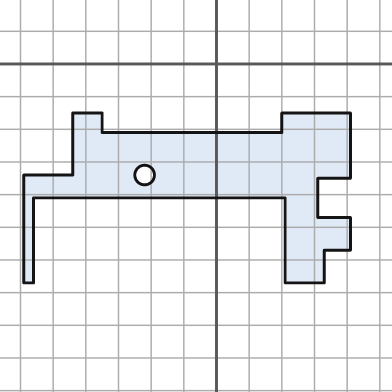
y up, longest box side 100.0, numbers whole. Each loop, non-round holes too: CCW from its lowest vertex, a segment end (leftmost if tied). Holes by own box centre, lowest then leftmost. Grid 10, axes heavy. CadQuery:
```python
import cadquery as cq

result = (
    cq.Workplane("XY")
    .moveTo(-59.0, -67.0)
    .lineTo(-56.0, -67.0)
    .lineTo(-56.0, -41.0)
    .lineTo(21.0, -41.0)
    .lineTo(21.0, -67.0)
    .lineTo(33.0, -67.0)
    .lineTo(33.0, -57.0)
    .lineTo(41.0, -57.0)
    .lineTo(41.0, -47.0)
    .lineTo(31.0, -47.0)
    .lineTo(31.0, -35.0)
    .lineTo(41.0, -35.0)
    .lineTo(41.0, -15.0)
    .lineTo(20.0, -15.0)
    .lineTo(20.0, -21.0)
    .lineTo(-35.0, -21.0)
    .lineTo(-35.0, -15.0)
    .lineTo(-44.0, -15.0)
    .lineTo(-44.0, -34.0)
    .lineTo(-59.0, -34.0)
    .close()
    .moveTo(-22.0, -34.0)
    .circle(3.0)
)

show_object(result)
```